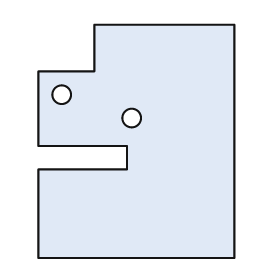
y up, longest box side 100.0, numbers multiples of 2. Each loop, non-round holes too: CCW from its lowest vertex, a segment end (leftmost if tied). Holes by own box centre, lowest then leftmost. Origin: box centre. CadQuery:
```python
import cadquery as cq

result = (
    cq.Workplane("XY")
    .moveTo(-42.0, -50.0)
    .lineTo(42.0, -50.0)
    .lineTo(42.0, 50.0)
    .lineTo(-18.0, 50.0)
    .lineTo(-18.0, 30.0)
    .lineTo(-42.0, 30.0)
    .lineTo(-42.0, -2.0)
    .lineTo(-4.0, -2.0)
    .lineTo(-4.0, -12.0)
    .lineTo(-42.0, -12.0)
    .close()
    .moveTo(-2.0, 10.0)
    .circle(4.0)
    .moveTo(-32.0, 20.0)
    .circle(4.0)
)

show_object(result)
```